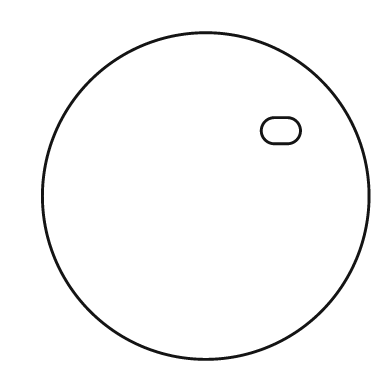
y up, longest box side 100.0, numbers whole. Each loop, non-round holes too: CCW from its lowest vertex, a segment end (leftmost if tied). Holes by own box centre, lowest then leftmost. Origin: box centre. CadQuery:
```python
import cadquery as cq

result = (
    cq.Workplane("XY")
    .moveTo(0.0, 0.0)
    .circle(50.0)
    .moveTo(21.0, 16.0)
    .lineTo(25.0, 16.0)
    .threePointArc((29.0, 20.0), (25.0, 24.0))
    .lineTo(21.0, 24.0)
    .threePointArc((17.0, 20.0), (21.0, 16.0))
    .close()
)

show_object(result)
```